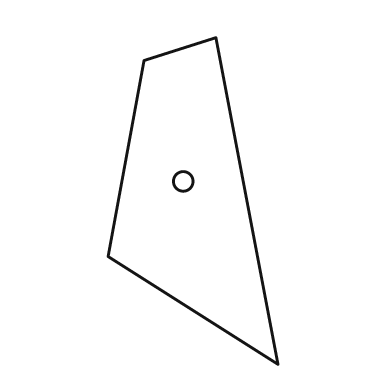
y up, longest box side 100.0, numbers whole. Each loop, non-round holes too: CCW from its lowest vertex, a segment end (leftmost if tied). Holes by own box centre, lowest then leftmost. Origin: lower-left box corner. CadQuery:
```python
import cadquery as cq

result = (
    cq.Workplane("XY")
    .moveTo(52.0, 0.0)
    .lineTo(33.0, 100.0)
    .lineTo(11.0, 93.0)
    .lineTo(0.0, 33.0)
    .close()
    .moveTo(23.0, 56.0)
    .circle(3.0)
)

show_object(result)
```